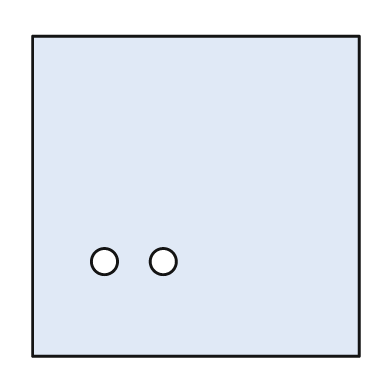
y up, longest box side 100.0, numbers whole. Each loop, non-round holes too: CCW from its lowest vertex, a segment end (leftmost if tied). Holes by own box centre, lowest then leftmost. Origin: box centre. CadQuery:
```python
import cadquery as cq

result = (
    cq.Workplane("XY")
    .moveTo(-50.0, -49.0)
    .lineTo(50.0, -49.0)
    .lineTo(50.0, 49.0)
    .lineTo(-50.0, 49.0)
    .close()
    .moveTo(-28.0, -20.0)
    .circle(4.0)
    .moveTo(-10.0, -20.0)
    .circle(4.0)
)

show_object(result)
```